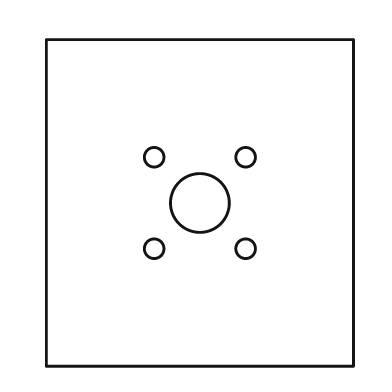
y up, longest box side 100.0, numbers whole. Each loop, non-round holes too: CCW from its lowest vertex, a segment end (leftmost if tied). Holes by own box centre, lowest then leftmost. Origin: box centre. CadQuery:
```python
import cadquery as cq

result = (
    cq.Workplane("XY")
    .moveTo(-47.0, -50.0)
    .lineTo(47.0, -50.0)
    .lineTo(47.0, 50.0)
    .lineTo(-47.0, 50.0)
    .close()
    .moveTo(-14.0, -14.0)
    .circle(3.0)
    .moveTo(14.0, -14.0)
    .circle(3.0)
    .moveTo(0.0, 0.0)
    .circle(9.0)
    .moveTo(-14.0, 14.0)
    .circle(3.0)
    .moveTo(14.0, 14.0)
    .circle(3.0)
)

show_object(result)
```